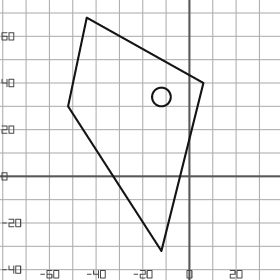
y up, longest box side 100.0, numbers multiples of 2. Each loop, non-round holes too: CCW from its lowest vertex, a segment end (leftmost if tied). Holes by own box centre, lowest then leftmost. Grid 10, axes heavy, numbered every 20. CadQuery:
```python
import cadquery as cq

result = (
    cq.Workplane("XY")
    .moveTo(-12.0, -32.0)
    .lineTo(6.0, 40.0)
    .lineTo(-44.0, 68.0)
    .lineTo(-52.0, 30.0)
    .close()
    .moveTo(-12.0, 34.0)
    .circle(4.0)
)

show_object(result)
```